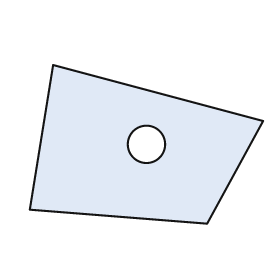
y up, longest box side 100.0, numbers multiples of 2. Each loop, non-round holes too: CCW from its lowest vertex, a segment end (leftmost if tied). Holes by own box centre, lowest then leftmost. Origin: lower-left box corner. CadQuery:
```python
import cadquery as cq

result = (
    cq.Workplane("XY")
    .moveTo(76.0, 0.0)
    .lineTo(100.0, 44.0)
    .lineTo(10.0, 68.0)
    .lineTo(0.0, 6.0)
    .close()
    .moveTo(50.0, 34.0)
    .circle(8.0)
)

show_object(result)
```